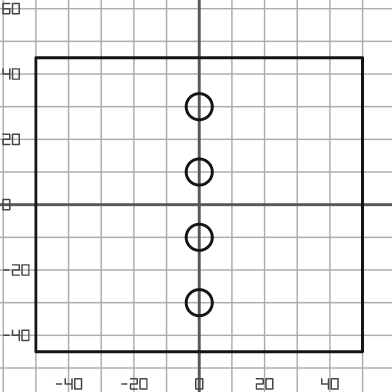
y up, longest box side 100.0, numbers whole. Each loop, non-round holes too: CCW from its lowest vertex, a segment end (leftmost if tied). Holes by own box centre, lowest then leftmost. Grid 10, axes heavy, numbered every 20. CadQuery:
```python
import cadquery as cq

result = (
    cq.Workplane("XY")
    .moveTo(-50.0, -45.0)
    .lineTo(50.0, -45.0)
    .lineTo(50.0, 45.0)
    .lineTo(-50.0, 45.0)
    .close()
    .moveTo(0.0, -30.0)
    .circle(4.0)
    .moveTo(0.0, -10.0)
    .circle(4.0)
    .moveTo(0.0, 10.0)
    .circle(4.0)
    .moveTo(0.0, 30.0)
    .circle(4.0)
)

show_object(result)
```